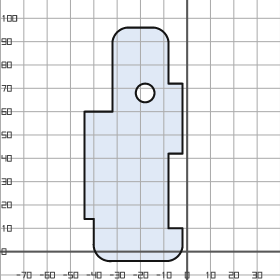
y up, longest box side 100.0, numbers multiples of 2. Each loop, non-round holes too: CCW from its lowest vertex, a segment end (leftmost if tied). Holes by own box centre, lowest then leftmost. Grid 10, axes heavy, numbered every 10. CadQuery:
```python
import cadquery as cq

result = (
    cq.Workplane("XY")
    .moveTo(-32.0, -4.0)
    .lineTo(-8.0, -4.0)
    .threePointArc((-4.0, -2.0), (-2.0, 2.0))
    .lineTo(-2.0, 10.0)
    .lineTo(-8.0, 10.0)
    .lineTo(-8.0, 42.0)
    .lineTo(-2.0, 42.0)
    .lineTo(-2.0, 72.0)
    .lineTo(-8.0, 72.0)
    .lineTo(-8.0, 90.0)
    .threePointArc((-10.0, 94.0), (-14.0, 96.0))
    .lineTo(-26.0, 96.0)
    .threePointArc((-30.0, 94.0), (-32.0, 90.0))
    .lineTo(-32.0, 60.0)
    .lineTo(-44.0, 60.0)
    .lineTo(-44.0, 14.0)
    .lineTo(-40.0, 14.0)
    .lineTo(-40.0, 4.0)
    .threePointArc((-38.0, -2.0), (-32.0, -4.0))
    .close()
    .moveTo(-18.0, 68.0)
    .circle(4.0)
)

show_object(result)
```